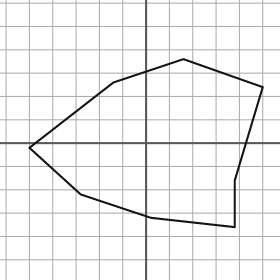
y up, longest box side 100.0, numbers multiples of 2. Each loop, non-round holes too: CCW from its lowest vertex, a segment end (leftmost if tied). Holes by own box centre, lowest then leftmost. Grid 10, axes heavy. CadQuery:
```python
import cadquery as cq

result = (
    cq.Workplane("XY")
    .moveTo(38.0, -36.0)
    .lineTo(38.0, -16.0)
    .lineTo(50.0, 24.0)
    .lineTo(16.0, 36.0)
    .lineTo(-14.0, 26.0)
    .lineTo(-50.0, -2.0)
    .lineTo(-28.0, -22.0)
    .lineTo(2.0, -32.0)
    .close()
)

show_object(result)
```